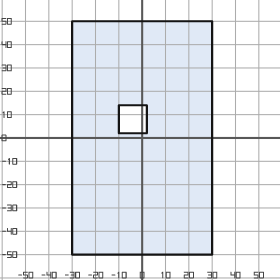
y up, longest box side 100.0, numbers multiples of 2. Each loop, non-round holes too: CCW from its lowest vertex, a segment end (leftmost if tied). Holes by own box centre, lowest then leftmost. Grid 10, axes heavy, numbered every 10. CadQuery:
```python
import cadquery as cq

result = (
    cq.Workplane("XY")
    .moveTo(-30.0, -50.0)
    .lineTo(30.0, -50.0)
    .lineTo(30.0, 50.0)
    .lineTo(-30.0, 50.0)
    .close()
    .moveTo(-10.0, 2.0)
    .lineTo(2.0, 2.0)
    .lineTo(2.0, 14.0)
    .lineTo(-10.0, 14.0)
    .close()
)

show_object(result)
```